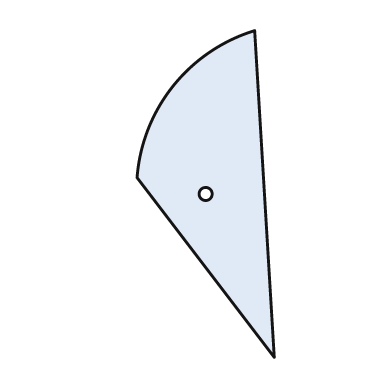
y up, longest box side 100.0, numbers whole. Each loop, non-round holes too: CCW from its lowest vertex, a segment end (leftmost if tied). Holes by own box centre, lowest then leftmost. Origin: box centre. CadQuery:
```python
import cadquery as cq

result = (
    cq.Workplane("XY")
    .moveTo(21.0, -50.0)
    .lineTo(15.0, 50.0)
    .threePointArc((-10.0, 33.0), (-21.0, 5.0))
    .close()
    .moveTo(0.0, 0.0)
    .circle(2.0)
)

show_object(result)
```